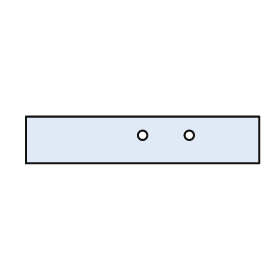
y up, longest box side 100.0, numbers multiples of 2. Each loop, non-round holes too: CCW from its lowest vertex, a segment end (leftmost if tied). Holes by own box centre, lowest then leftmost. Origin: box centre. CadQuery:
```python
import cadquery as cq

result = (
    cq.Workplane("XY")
    .moveTo(-50.0, -10.0)
    .lineTo(50.0, -10.0)
    .lineTo(50.0, 10.0)
    .lineTo(-50.0, 10.0)
    .close()
    .moveTo(0.0, 2.0)
    .circle(2.0)
    .moveTo(20.0, 2.0)
    .circle(2.0)
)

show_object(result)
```